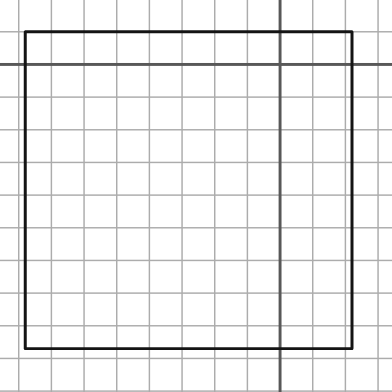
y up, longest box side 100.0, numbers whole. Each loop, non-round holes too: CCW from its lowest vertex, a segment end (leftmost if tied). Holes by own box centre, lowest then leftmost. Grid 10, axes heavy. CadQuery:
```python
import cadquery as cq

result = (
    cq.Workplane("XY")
    .moveTo(-78.0, -87.0)
    .lineTo(22.0, -87.0)
    .lineTo(22.0, 10.0)
    .lineTo(-78.0, 10.0)
    .close()
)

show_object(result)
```